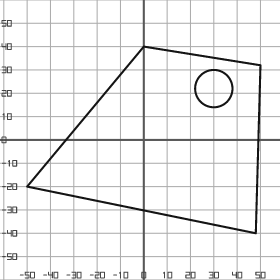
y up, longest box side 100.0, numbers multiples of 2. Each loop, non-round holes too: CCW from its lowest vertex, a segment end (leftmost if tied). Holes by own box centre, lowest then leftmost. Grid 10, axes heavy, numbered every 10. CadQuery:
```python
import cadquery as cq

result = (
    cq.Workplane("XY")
    .moveTo(48.0, -40.0)
    .lineTo(50.0, 32.0)
    .lineTo(0.0, 40.0)
    .lineTo(-50.0, -20.0)
    .close()
    .moveTo(30.0, 22.0)
    .circle(8.0)
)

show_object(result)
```